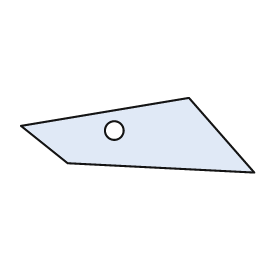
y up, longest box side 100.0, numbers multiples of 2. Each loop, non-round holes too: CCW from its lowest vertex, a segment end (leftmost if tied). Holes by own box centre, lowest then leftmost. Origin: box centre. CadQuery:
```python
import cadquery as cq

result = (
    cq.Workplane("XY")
    .moveTo(50.0, -16.0)
    .lineTo(22.0, 16.0)
    .lineTo(-50.0, 4.0)
    .lineTo(-30.0, -12.0)
    .close()
    .moveTo(-10.0, 2.0)
    .circle(4.0)
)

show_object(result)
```